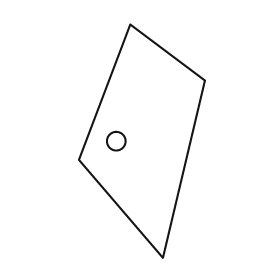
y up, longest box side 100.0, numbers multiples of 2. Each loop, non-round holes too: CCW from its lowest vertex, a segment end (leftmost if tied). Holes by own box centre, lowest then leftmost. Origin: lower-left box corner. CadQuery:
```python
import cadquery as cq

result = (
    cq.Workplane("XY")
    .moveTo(36.0, 0.0)
    .lineTo(54.0, 76.0)
    .lineTo(22.0, 100.0)
    .lineTo(0.0, 42.0)
    .close()
    .moveTo(16.0, 50.0)
    .circle(4.0)
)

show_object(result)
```